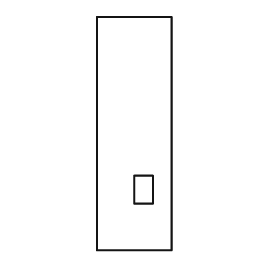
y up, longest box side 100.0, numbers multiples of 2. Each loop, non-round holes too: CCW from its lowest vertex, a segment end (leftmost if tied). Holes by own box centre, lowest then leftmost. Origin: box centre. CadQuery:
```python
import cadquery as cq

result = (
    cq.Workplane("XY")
    .moveTo(-16.0, -50.0)
    .lineTo(16.0, -50.0)
    .lineTo(16.0, 50.0)
    .lineTo(-16.0, 50.0)
    .close()
    .moveTo(0.0, -30.0)
    .lineTo(8.0, -30.0)
    .lineTo(8.0, -18.0)
    .lineTo(0.0, -18.0)
    .close()
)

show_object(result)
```